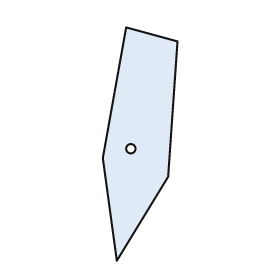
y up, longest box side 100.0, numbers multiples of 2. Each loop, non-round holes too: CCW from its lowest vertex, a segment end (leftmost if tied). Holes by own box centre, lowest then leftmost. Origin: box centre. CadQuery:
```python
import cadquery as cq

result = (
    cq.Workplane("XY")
    .moveTo(-10.0, -50.0)
    .lineTo(12.0, -14.0)
    .lineTo(16.0, 44.0)
    .lineTo(-6.0, 50.0)
    .lineTo(-16.0, -6.0)
    .close()
    .moveTo(-4.0, -2.0)
    .circle(2.0)
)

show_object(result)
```